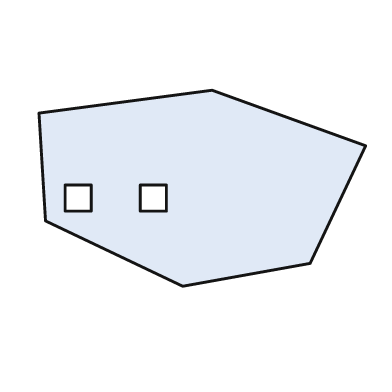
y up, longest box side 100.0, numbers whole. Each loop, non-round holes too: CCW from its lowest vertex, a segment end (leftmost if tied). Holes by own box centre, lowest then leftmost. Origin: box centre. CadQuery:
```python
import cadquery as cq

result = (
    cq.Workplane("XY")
    .moveTo(-6.0, -30.0)
    .lineTo(33.0, -23.0)
    .lineTo(50.0, 13.0)
    .lineTo(3.0, 30.0)
    .lineTo(-50.0, 23.0)
    .lineTo(-48.0, -10.0)
    .close()
    .moveTo(-42.0, -7.0)
    .lineTo(-34.0, -7.0)
    .lineTo(-34.0, 1.0)
    .lineTo(-42.0, 1.0)
    .close()
    .moveTo(-19.0, -7.0)
    .lineTo(-11.0, -7.0)
    .lineTo(-11.0, 1.0)
    .lineTo(-19.0, 1.0)
    .close()
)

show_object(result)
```